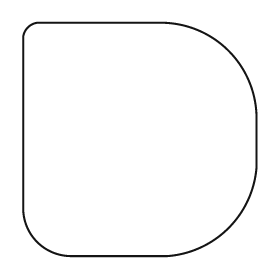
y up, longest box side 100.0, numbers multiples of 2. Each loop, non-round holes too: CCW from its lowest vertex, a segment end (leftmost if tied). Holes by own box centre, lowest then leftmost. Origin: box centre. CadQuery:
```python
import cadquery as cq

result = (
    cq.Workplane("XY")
    .moveTo(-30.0, -50.0)
    .lineTo(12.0, -50.0)
    .threePointArc((38.0, -38.0), (50.0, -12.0))
    .lineTo(50.0, 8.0)
    .threePointArc((38.0, 38.0), (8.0, 50.0))
    .lineTo(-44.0, 50.0)
    .threePointArc((-48.0, 48.0), (-50.0, 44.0))
    .lineTo(-50.0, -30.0)
    .threePointArc((-44.0, -44.0), (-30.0, -50.0))
    .close()
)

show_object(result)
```